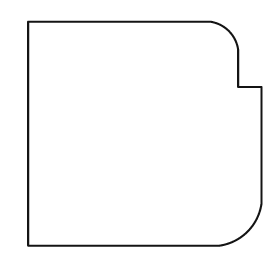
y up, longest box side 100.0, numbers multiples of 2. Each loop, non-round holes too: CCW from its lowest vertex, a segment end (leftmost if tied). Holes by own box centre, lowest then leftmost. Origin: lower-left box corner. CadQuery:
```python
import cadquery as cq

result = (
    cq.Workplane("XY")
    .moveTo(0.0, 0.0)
    .lineTo(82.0, 0.0)
    .threePointArc((94.0, 6.0), (100.0, 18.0))
    .lineTo(100.0, 68.0)
    .lineTo(90.0, 68.0)
    .lineTo(90.0, 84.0)
    .threePointArc((86.0, 92.0), (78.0, 96.0))
    .lineTo(0.0, 96.0)
    .close()
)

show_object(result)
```